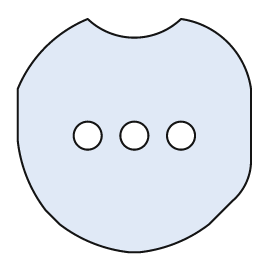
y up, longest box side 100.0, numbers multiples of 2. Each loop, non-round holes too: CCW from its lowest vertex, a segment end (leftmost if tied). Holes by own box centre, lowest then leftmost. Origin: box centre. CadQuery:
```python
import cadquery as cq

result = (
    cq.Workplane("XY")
    .moveTo(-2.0, -50.0)
    .lineTo(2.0, -50.0)
    .threePointArc((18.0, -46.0), (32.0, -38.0))
    .lineTo(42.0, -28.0)
    .threePointArc((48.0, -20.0), (50.0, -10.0))
    .lineTo(50.0, 20.0)
    .threePointArc((40.0, 40.0), (20.0, 50.0))
    .threePointArc((0.0, 42.0), (-20.0, 50.0))
    .threePointArc((-38.0, 38.0), (-50.0, 20.0))
    .lineTo(-50.0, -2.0)
    .threePointArc((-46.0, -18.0), (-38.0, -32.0))
    .lineTo(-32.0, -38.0)
    .threePointArc((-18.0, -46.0), (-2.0, -50.0))
    .close()
    .moveTo(-20.0, 0.0)
    .circle(6.0)
    .moveTo(0.0, 0.0)
    .circle(6.0)
    .moveTo(20.0, 0.0)
    .circle(6.0)
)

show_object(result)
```